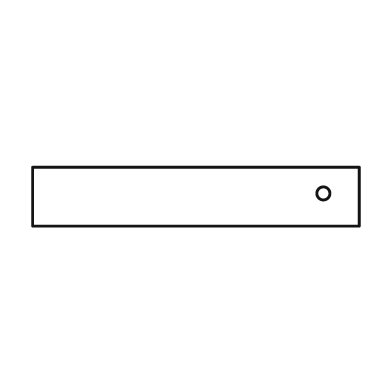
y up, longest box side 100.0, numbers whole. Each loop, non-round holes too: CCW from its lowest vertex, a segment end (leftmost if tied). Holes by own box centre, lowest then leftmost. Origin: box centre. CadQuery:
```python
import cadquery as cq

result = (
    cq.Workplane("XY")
    .moveTo(-50.0, -9.0)
    .lineTo(50.0, -9.0)
    .lineTo(50.0, 9.0)
    .lineTo(-50.0, 9.0)
    .close()
    .moveTo(39.0, 1.0)
    .circle(2.0)
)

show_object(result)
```